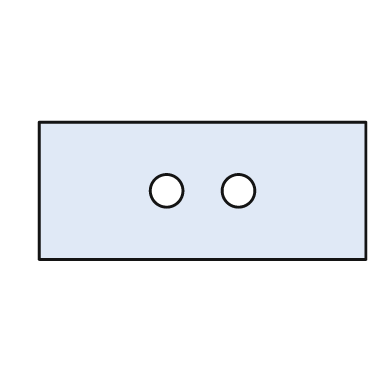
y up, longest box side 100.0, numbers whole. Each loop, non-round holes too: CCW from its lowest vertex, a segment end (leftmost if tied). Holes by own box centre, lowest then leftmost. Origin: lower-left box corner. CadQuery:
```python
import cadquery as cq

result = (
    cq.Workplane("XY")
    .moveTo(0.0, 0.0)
    .lineTo(100.0, 0.0)
    .lineTo(100.0, 42.0)
    .lineTo(0.0, 42.0)
    .close()
    .moveTo(39.0, 21.0)
    .circle(5.0)
    .moveTo(61.0, 21.0)
    .circle(5.0)
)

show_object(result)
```